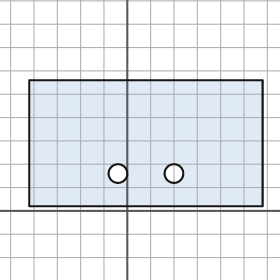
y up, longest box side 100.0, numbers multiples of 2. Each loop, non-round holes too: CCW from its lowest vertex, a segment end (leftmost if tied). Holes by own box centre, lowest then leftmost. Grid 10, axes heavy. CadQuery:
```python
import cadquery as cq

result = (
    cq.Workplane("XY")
    .moveTo(-42.0, 2.0)
    .lineTo(58.0, 2.0)
    .lineTo(58.0, 56.0)
    .lineTo(-42.0, 56.0)
    .close()
    .moveTo(-4.0, 16.0)
    .circle(4.0)
    .moveTo(20.0, 16.0)
    .circle(4.0)
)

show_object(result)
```